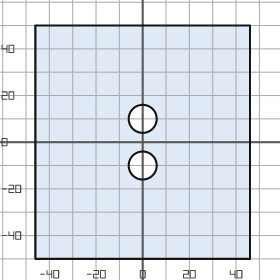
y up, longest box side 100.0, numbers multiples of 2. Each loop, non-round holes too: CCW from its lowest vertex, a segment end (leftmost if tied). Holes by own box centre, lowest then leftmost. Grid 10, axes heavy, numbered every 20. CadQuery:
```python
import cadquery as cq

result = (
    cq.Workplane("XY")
    .moveTo(-46.0, -50.0)
    .lineTo(46.0, -50.0)
    .lineTo(46.0, 50.0)
    .lineTo(-46.0, 50.0)
    .close()
    .moveTo(0.0, -10.0)
    .circle(6.0)
    .moveTo(0.0, 10.0)
    .circle(6.0)
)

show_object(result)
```